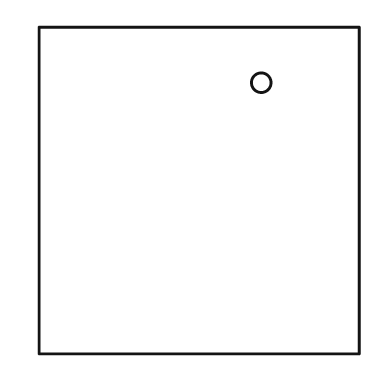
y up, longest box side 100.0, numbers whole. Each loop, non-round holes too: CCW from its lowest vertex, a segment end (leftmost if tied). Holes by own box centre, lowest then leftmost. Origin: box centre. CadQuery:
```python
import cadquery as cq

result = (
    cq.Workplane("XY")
    .moveTo(-49.0, -50.0)
    .lineTo(49.0, -50.0)
    .lineTo(49.0, 50.0)
    .lineTo(-49.0, 50.0)
    .close()
    .moveTo(19.0, 33.0)
    .circle(3.0)
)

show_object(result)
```